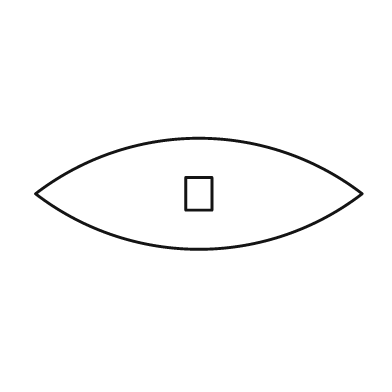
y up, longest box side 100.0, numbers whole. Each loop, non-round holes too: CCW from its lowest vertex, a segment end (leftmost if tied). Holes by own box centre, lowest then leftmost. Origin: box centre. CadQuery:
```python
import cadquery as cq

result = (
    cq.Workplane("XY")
    .moveTo(-50.0, 0.0)
    .threePointArc((0.0, -17.0), (50.0, 0.0))
    .threePointArc((0.0, 17.0), (-50.0, 0.0))
    .close()
    .moveTo(-4.0, -5.0)
    .lineTo(4.0, -5.0)
    .lineTo(4.0, 5.0)
    .lineTo(-4.0, 5.0)
    .close()
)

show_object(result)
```